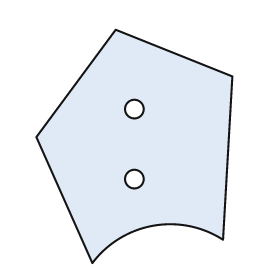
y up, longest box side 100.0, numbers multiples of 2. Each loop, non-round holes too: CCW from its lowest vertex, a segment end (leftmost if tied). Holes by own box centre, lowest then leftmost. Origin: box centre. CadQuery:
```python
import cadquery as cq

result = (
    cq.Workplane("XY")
    .moveTo(-18.0, -50.0)
    .threePointArc((8.0, -34.0), (38.0, -40.0))
    .lineTo(42.0, 30.0)
    .lineTo(-8.0, 50.0)
    .lineTo(-42.0, 4.0)
    .close()
    .moveTo(0.0, -14.0)
    .circle(4.0)
    .moveTo(0.0, 16.0)
    .circle(4.0)
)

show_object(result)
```